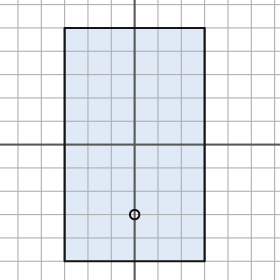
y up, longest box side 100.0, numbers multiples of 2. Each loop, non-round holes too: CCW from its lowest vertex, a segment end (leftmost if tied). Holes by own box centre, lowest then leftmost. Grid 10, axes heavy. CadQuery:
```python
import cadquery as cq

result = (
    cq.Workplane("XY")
    .moveTo(-30.0, -50.0)
    .lineTo(30.0, -50.0)
    .lineTo(30.0, 50.0)
    .lineTo(-30.0, 50.0)
    .close()
    .moveTo(0.0, -30.0)
    .circle(2.0)
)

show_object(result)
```